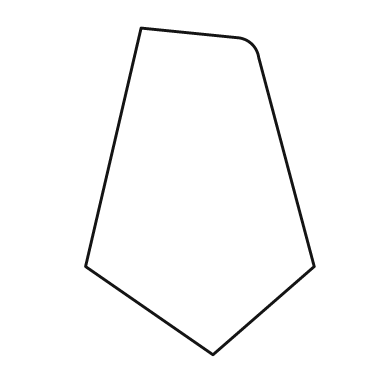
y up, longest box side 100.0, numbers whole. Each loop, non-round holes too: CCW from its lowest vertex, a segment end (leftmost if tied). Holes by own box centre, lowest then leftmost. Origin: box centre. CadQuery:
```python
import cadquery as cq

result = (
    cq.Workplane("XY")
    .moveTo(4.0, -50.0)
    .lineTo(35.0, -23.0)
    .lineTo(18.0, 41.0)
    .threePointArc((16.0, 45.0), (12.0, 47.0))
    .lineTo(-18.0, 50.0)
    .lineTo(-35.0, -23.0)
    .close()
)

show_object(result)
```